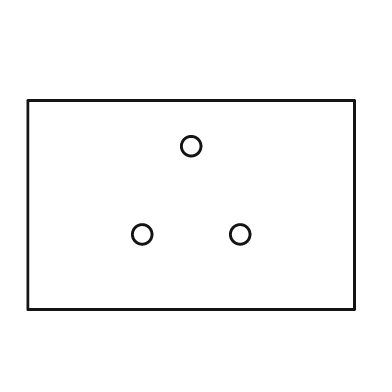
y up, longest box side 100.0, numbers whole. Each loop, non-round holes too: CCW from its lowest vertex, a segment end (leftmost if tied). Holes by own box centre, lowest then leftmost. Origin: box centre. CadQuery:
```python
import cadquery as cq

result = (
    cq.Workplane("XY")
    .moveTo(-50.0, -32.0)
    .lineTo(50.0, -32.0)
    .lineTo(50.0, 32.0)
    .lineTo(-50.0, 32.0)
    .close()
    .moveTo(-15.0, -9.0)
    .circle(3.0)
    .moveTo(15.0, -9.0)
    .circle(3.0)
    .moveTo(0.0, 18.0)
    .circle(3.0)
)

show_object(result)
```